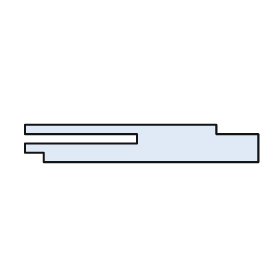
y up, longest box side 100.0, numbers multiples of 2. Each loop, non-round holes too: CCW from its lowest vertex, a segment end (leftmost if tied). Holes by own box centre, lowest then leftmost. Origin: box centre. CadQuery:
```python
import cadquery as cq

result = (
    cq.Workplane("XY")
    .moveTo(-42.0, -8.0)
    .lineTo(50.0, -8.0)
    .lineTo(50.0, 4.0)
    .lineTo(32.0, 4.0)
    .lineTo(32.0, 8.0)
    .lineTo(-50.0, 8.0)
    .lineTo(-50.0, 4.0)
    .lineTo(-2.0, 4.0)
    .lineTo(-2.0, 0.0)
    .lineTo(-50.0, 0.0)
    .lineTo(-50.0, -4.0)
    .lineTo(-42.0, -4.0)
    .close()
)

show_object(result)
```